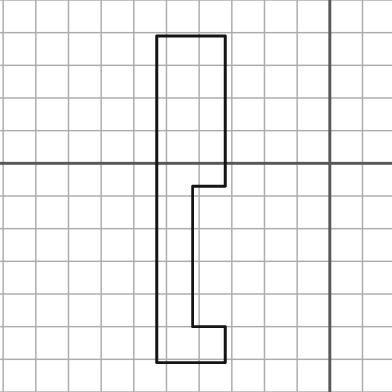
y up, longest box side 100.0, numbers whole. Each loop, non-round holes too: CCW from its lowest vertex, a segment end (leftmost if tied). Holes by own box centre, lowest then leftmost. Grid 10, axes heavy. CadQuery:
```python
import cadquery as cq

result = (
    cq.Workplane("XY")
    .moveTo(-53.0, -61.0)
    .lineTo(-32.0, -61.0)
    .lineTo(-32.0, -50.0)
    .lineTo(-42.0, -50.0)
    .lineTo(-42.0, -7.0)
    .lineTo(-32.0, -7.0)
    .lineTo(-32.0, 39.0)
    .lineTo(-53.0, 39.0)
    .close()
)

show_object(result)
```